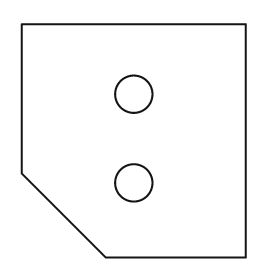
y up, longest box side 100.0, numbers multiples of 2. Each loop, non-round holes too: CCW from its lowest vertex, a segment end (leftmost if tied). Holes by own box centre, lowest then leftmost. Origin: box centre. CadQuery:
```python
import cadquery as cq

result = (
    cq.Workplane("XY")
    .moveTo(-12.0, -50.0)
    .lineTo(48.0, -50.0)
    .lineTo(48.0, 50.0)
    .lineTo(-48.0, 50.0)
    .lineTo(-48.0, -14.0)
    .close()
    .moveTo(0.0, -18.0)
    .circle(8.0)
    .moveTo(0.0, 20.0)
    .circle(8.0)
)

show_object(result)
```